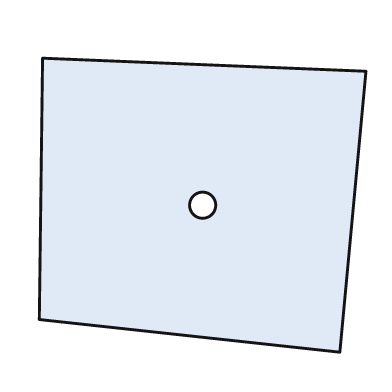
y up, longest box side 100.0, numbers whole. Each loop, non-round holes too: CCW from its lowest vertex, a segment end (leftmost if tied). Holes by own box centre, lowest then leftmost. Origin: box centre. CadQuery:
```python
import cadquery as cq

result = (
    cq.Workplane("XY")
    .moveTo(42.0, -45.0)
    .lineTo(50.0, 41.0)
    .lineTo(-49.0, 45.0)
    .lineTo(-50.0, -35.0)
    .close()
    .moveTo(0.0, 0.0)
    .circle(4.0)
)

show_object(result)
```